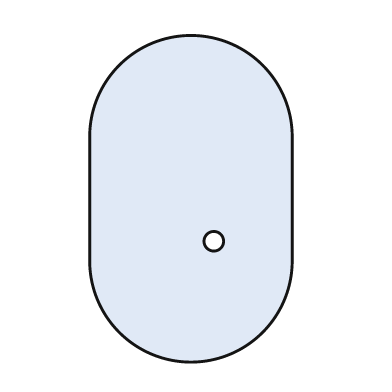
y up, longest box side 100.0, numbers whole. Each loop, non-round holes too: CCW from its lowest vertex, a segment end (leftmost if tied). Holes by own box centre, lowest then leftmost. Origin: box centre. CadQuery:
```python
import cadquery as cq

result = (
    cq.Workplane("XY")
    .moveTo(-31.0, -19.0)
    .threePointArc((0.0, -50.0), (31.0, -19.0))
    .lineTo(31.0, 19.0)
    .threePointArc((0.0, 50.0), (-31.0, 19.0))
    .close()
    .moveTo(7.0, -13.0)
    .circle(3.0)
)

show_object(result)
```